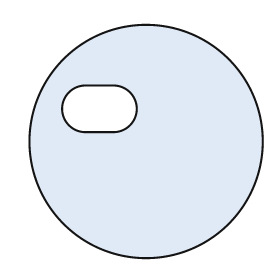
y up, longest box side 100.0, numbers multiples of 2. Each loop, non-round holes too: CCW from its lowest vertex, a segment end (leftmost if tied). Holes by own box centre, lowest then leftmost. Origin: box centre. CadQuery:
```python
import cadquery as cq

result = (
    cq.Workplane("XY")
    .moveTo(0.0, 0.0)
    .circle(50.0)
    .moveTo(-26.0, 4.0)
    .lineTo(-14.0, 4.0)
    .threePointArc((-4.0, 14.0), (-14.0, 24.0))
    .lineTo(-26.0, 24.0)
    .threePointArc((-36.0, 14.0), (-26.0, 4.0))
    .close()
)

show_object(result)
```